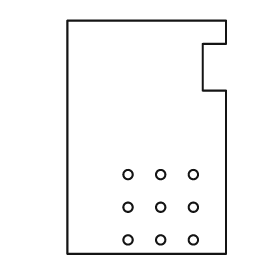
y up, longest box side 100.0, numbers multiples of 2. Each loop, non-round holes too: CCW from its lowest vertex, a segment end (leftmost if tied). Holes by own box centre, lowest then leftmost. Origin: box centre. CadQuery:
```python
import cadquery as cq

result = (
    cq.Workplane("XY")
    .moveTo(-34.0, -50.0)
    .lineTo(34.0, -50.0)
    .lineTo(34.0, 20.0)
    .lineTo(24.0, 20.0)
    .lineTo(24.0, 40.0)
    .lineTo(34.0, 40.0)
    .lineTo(34.0, 50.0)
    .lineTo(-34.0, 50.0)
    .close()
    .moveTo(-8.0, -44.0)
    .circle(2.0)
    .moveTo(6.0, -44.0)
    .circle(2.0)
    .moveTo(20.0, -44.0)
    .circle(2.0)
    .moveTo(-8.0, -30.0)
    .circle(2.0)
    .moveTo(6.0, -30.0)
    .circle(2.0)
    .moveTo(20.0, -30.0)
    .circle(2.0)
    .moveTo(-8.0, -16.0)
    .circle(2.0)
    .moveTo(6.0, -16.0)
    .circle(2.0)
    .moveTo(20.0, -16.0)
    .circle(2.0)
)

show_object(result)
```